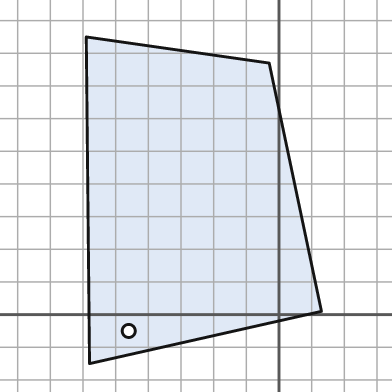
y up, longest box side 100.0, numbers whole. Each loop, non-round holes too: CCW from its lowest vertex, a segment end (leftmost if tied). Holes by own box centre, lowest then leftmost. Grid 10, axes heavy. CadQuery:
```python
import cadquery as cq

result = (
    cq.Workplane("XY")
    .moveTo(-58.0, -15.0)
    .lineTo(13.0, 1.0)
    .lineTo(-3.0, 77.0)
    .lineTo(-59.0, 85.0)
    .close()
    .moveTo(-46.0, -5.0)
    .circle(2.0)
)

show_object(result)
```